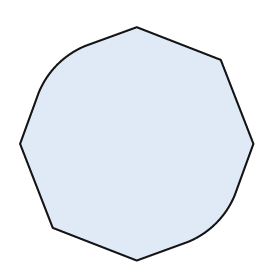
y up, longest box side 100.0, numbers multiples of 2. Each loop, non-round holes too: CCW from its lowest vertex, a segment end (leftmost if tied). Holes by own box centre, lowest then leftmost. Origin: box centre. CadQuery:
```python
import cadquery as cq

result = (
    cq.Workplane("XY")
    .moveTo(0.0, -50.0)
    .lineTo(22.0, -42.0)
    .threePointArc((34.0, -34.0), (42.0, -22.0))
    .lineTo(50.0, 0.0)
    .lineTo(36.0, 36.0)
    .lineTo(0.0, 50.0)
    .lineTo(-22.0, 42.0)
    .threePointArc((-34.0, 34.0), (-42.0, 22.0))
    .lineTo(-50.0, 0.0)
    .lineTo(-36.0, -36.0)
    .close()
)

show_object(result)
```